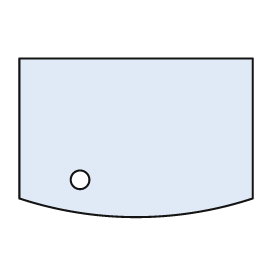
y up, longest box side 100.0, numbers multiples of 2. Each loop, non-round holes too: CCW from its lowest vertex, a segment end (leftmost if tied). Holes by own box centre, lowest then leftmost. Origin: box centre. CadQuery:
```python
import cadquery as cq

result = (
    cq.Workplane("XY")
    .moveTo(-50.0, -26.0)
    .threePointArc((0.0, -34.0), (50.0, -26.0))
    .lineTo(50.0, 34.0)
    .lineTo(-50.0, 34.0)
    .close()
    .moveTo(-24.0, -18.0)
    .circle(4.0)
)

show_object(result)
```